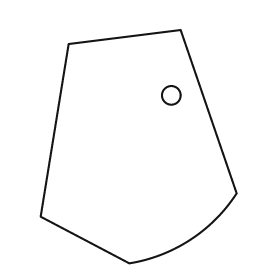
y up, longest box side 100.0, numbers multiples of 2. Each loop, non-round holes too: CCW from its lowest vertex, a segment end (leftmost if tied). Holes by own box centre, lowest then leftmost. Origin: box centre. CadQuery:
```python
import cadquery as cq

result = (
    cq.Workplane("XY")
    .moveTo(-4.0, -50.0)
    .threePointArc((22.0, -40.0), (42.0, -20.0))
    .lineTo(18.0, 50.0)
    .lineTo(-30.0, 44.0)
    .lineTo(-42.0, -30.0)
    .close()
    .moveTo(14.0, 22.0)
    .circle(4.0)
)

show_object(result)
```